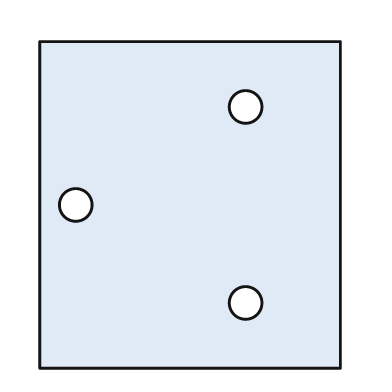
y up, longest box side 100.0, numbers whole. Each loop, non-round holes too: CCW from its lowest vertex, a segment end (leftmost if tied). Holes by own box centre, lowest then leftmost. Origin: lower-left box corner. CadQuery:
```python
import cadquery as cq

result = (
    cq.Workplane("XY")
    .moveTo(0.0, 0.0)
    .lineTo(92.0, 0.0)
    .lineTo(92.0, 100.0)
    .lineTo(0.0, 100.0)
    .close()
    .moveTo(63.0, 20.0)
    .circle(5.0)
    .moveTo(11.0, 50.0)
    .circle(5.0)
    .moveTo(63.0, 80.0)
    .circle(5.0)
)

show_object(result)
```